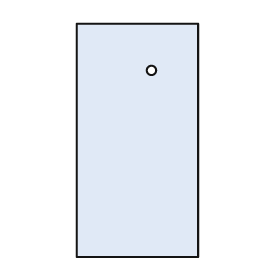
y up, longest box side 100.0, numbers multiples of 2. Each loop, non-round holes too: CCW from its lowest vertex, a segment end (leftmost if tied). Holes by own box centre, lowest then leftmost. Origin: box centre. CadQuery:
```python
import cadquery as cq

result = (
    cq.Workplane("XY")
    .moveTo(-26.0, -50.0)
    .lineTo(26.0, -50.0)
    .lineTo(26.0, 50.0)
    .lineTo(-26.0, 50.0)
    .close()
    .moveTo(6.0, 30.0)
    .circle(2.0)
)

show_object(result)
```